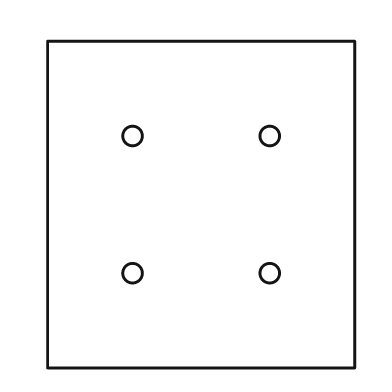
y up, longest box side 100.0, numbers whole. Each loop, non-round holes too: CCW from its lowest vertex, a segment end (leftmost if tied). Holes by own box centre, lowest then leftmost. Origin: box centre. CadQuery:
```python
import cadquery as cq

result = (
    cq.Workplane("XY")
    .moveTo(-47.0, -50.0)
    .lineTo(47.0, -50.0)
    .lineTo(47.0, 50.0)
    .lineTo(-47.0, 50.0)
    .close()
    .moveTo(-21.0, -21.0)
    .circle(3.0)
    .moveTo(21.0, -21.0)
    .circle(3.0)
    .moveTo(-21.0, 21.0)
    .circle(3.0)
    .moveTo(21.0, 21.0)
    .circle(3.0)
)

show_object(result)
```